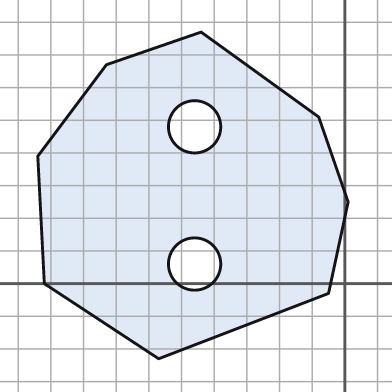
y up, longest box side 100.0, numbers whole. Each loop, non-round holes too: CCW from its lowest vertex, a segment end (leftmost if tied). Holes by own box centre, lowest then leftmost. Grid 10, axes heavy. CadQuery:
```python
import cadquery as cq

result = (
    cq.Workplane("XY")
    .moveTo(-57.0, -23.0)
    .lineTo(-5.0, -3.0)
    .lineTo(1.0, 25.0)
    .lineTo(-8.0, 51.0)
    .lineTo(-44.0, 77.0)
    .lineTo(-73.0, 67.0)
    .lineTo(-94.0, 39.0)
    .lineTo(-92.0, 0.0)
    .close()
    .moveTo(-46.0, 6.0)
    .circle(8.0)
    .moveTo(-46.0, 48.0)
    .circle(8.0)
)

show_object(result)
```